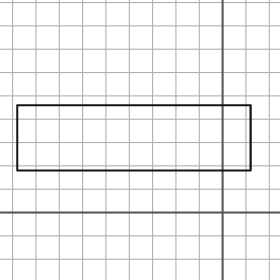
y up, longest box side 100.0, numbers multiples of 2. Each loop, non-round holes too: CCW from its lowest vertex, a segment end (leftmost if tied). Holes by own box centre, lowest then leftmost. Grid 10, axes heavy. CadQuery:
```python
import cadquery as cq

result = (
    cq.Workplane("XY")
    .moveTo(-88.0, 18.0)
    .lineTo(12.0, 18.0)
    .lineTo(12.0, 46.0)
    .lineTo(-88.0, 46.0)
    .close()
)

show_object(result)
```